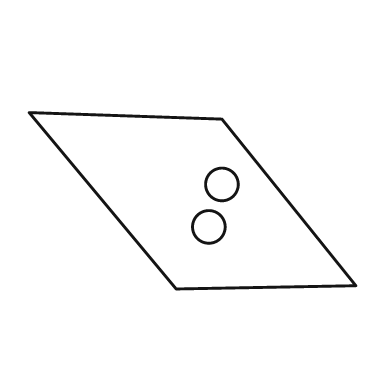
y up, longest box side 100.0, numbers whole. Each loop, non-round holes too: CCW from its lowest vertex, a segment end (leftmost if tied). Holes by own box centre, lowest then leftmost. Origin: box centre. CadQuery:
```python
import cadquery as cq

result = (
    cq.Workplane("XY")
    .moveTo(-5.0, -27.0)
    .lineTo(50.0, -26.0)
    .lineTo(9.0, 25.0)
    .lineTo(-50.0, 27.0)
    .close()
    .moveTo(5.0, -8.0)
    .circle(5.0)
    .moveTo(9.0, 5.0)
    .circle(5.0)
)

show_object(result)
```